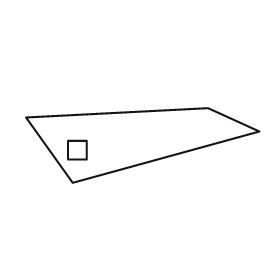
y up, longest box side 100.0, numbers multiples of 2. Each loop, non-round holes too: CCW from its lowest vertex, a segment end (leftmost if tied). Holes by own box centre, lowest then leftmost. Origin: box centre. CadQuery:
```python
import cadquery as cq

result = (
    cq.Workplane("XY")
    .moveTo(-30.0, -16.0)
    .lineTo(50.0, 6.0)
    .lineTo(28.0, 16.0)
    .lineTo(-50.0, 12.0)
    .close()
    .moveTo(-32.0, -6.0)
    .lineTo(-24.0, -6.0)
    .lineTo(-24.0, 2.0)
    .lineTo(-32.0, 2.0)
    .close()
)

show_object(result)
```